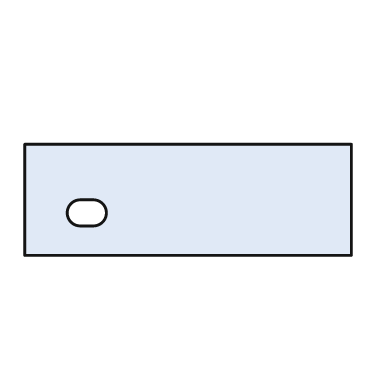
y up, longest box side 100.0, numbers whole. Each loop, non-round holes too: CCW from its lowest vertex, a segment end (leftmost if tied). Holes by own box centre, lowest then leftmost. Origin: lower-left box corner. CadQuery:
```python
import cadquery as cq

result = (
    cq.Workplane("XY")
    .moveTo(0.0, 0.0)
    .lineTo(100.0, 0.0)
    .lineTo(100.0, 34.0)
    .lineTo(0.0, 34.0)
    .close()
    .moveTo(17.0, 9.0)
    .lineTo(21.0, 9.0)
    .threePointArc((25.0, 13.0), (21.0, 17.0))
    .lineTo(17.0, 17.0)
    .threePointArc((13.0, 13.0), (17.0, 9.0))
    .close()
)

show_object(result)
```